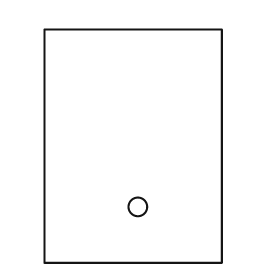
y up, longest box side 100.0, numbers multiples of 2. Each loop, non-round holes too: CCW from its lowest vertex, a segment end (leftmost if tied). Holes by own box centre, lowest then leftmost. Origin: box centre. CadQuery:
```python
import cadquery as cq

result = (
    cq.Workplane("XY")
    .moveTo(-38.0, -50.0)
    .lineTo(38.0, -50.0)
    .lineTo(38.0, 50.0)
    .lineTo(-38.0, 50.0)
    .close()
    .moveTo(2.0, -26.0)
    .circle(4.0)
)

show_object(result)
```